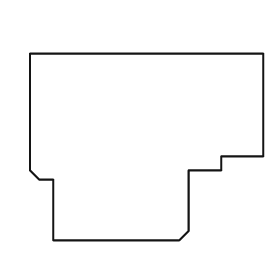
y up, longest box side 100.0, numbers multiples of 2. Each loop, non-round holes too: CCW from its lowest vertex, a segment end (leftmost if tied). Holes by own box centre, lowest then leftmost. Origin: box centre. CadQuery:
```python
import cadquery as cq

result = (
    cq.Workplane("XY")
    .moveTo(-40.0, -40.0)
    .lineTo(14.0, -40.0)
    .lineTo(18.0, -36.0)
    .lineTo(18.0, -10.0)
    .lineTo(32.0, -10.0)
    .lineTo(32.0, -4.0)
    .lineTo(50.0, -4.0)
    .lineTo(50.0, 40.0)
    .lineTo(-50.0, 40.0)
    .lineTo(-50.0, -10.0)
    .lineTo(-46.0, -14.0)
    .lineTo(-40.0, -14.0)
    .close()
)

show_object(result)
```